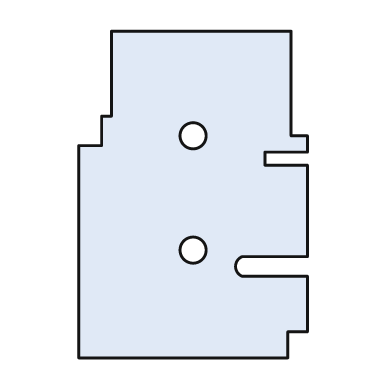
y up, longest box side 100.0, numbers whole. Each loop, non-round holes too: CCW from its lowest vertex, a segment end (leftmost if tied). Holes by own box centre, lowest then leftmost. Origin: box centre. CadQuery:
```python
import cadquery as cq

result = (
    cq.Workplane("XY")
    .moveTo(-35.0, -50.0)
    .lineTo(29.0, -50.0)
    .lineTo(29.0, -42.0)
    .lineTo(35.0, -42.0)
    .lineTo(35.0, -25.0)
    .lineTo(15.0, -25.0)
    .threePointArc((13.0, -22.0), (15.0, -19.0))
    .lineTo(35.0, -19.0)
    .lineTo(35.0, 9.0)
    .lineTo(22.0, 9.0)
    .lineTo(22.0, 13.0)
    .lineTo(35.0, 13.0)
    .lineTo(35.0, 18.0)
    .lineTo(30.0, 18.0)
    .lineTo(30.0, 50.0)
    .lineTo(-25.0, 50.0)
    .lineTo(-25.0, 24.0)
    .lineTo(-28.0, 24.0)
    .lineTo(-28.0, 15.0)
    .lineTo(-35.0, 15.0)
    .close()
    .moveTo(0.0, -17.0)
    .circle(4.0)
    .moveTo(0.0, 18.0)
    .circle(4.0)
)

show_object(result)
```